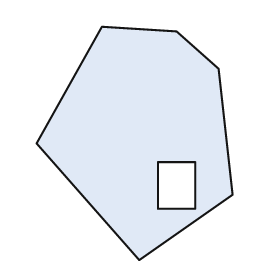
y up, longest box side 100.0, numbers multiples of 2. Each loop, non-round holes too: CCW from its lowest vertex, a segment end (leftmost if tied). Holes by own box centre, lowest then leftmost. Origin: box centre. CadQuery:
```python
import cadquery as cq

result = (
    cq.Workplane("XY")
    .moveTo(2.0, -50.0)
    .lineTo(42.0, -22.0)
    .lineTo(36.0, 32.0)
    .lineTo(18.0, 48.0)
    .lineTo(-14.0, 50.0)
    .lineTo(-42.0, 0.0)
    .close()
    .moveTo(10.0, -28.0)
    .lineTo(26.0, -28.0)
    .lineTo(26.0, -8.0)
    .lineTo(10.0, -8.0)
    .close()
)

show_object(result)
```